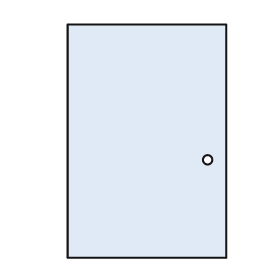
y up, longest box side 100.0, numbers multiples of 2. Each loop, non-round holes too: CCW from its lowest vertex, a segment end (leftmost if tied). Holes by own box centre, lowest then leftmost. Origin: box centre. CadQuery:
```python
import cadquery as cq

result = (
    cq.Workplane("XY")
    .moveTo(-34.0, -50.0)
    .lineTo(34.0, -50.0)
    .lineTo(34.0, 50.0)
    .lineTo(-34.0, 50.0)
    .close()
    .moveTo(26.0, -8.0)
    .circle(2.0)
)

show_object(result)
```